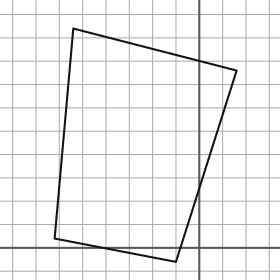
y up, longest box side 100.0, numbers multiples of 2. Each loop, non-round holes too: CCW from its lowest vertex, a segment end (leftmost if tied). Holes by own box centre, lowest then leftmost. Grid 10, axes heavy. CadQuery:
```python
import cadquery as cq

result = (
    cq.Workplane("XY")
    .moveTo(-10.0, -6.0)
    .lineTo(16.0, 76.0)
    .lineTo(-54.0, 94.0)
    .lineTo(-62.0, 4.0)
    .close()
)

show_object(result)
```